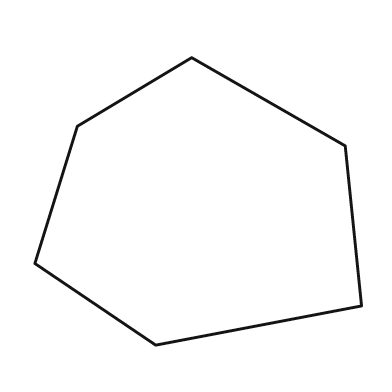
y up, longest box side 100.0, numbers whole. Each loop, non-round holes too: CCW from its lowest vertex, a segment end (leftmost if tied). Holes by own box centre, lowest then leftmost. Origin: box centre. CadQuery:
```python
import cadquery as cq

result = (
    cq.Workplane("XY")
    .moveTo(-13.0, -44.0)
    .lineTo(50.0, -32.0)
    .lineTo(45.0, 17.0)
    .lineTo(-2.0, 44.0)
    .lineTo(-37.0, 23.0)
    .lineTo(-50.0, -19.0)
    .close()
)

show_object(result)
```